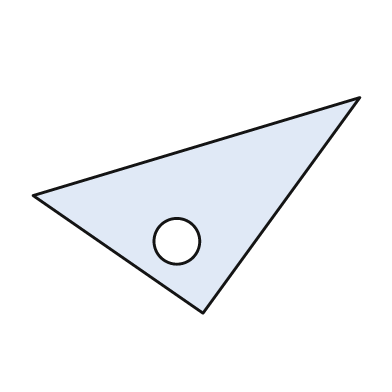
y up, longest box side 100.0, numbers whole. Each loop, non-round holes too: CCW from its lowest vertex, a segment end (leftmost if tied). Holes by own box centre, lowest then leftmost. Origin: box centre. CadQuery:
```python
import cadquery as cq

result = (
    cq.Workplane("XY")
    .moveTo(2.0, -33.0)
    .lineTo(50.0, 33.0)
    .lineTo(-50.0, 3.0)
    .close()
    .moveTo(-6.0, -11.0)
    .circle(7.0)
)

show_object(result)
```